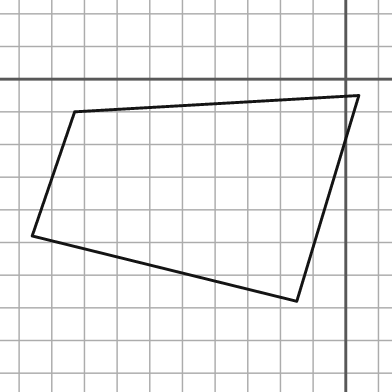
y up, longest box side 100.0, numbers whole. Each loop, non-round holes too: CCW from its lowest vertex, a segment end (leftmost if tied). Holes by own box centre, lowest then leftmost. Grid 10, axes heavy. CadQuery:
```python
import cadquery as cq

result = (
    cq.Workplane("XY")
    .moveTo(-15.0, -68.0)
    .lineTo(4.0, -5.0)
    .lineTo(-83.0, -10.0)
    .lineTo(-96.0, -48.0)
    .close()
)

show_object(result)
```